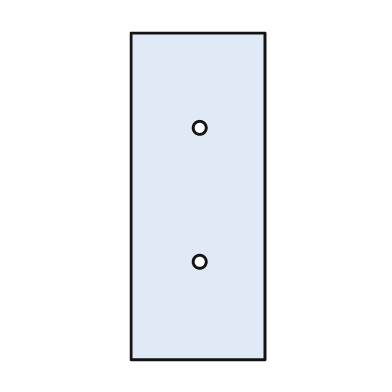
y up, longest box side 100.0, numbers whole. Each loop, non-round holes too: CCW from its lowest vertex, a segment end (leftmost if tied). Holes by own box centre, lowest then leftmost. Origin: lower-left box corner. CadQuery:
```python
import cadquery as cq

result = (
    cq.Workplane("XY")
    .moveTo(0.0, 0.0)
    .lineTo(41.0, 0.0)
    .lineTo(41.0, 100.0)
    .lineTo(0.0, 100.0)
    .close()
    .moveTo(21.0, 30.0)
    .circle(2.0)
    .moveTo(21.0, 71.0)
    .circle(2.0)
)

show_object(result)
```